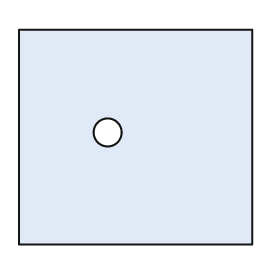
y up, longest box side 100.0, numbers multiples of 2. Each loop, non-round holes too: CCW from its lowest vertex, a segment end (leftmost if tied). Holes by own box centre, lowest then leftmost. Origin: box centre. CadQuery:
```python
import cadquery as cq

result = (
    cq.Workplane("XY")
    .moveTo(-50.0, -46.0)
    .lineTo(50.0, -46.0)
    .lineTo(50.0, 46.0)
    .lineTo(-50.0, 46.0)
    .close()
    .moveTo(-12.0, 2.0)
    .circle(6.0)
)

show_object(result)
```